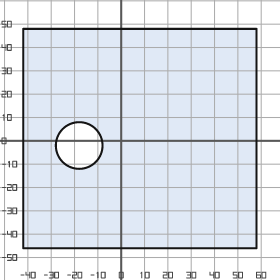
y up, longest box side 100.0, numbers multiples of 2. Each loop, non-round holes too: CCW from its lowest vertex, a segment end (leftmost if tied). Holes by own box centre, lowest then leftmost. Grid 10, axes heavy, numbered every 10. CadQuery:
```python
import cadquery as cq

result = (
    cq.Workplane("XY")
    .moveTo(-42.0, -46.0)
    .lineTo(58.0, -46.0)
    .lineTo(58.0, 48.0)
    .lineTo(-42.0, 48.0)
    .close()
    .moveTo(-18.0, -2.0)
    .circle(10.0)
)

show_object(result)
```